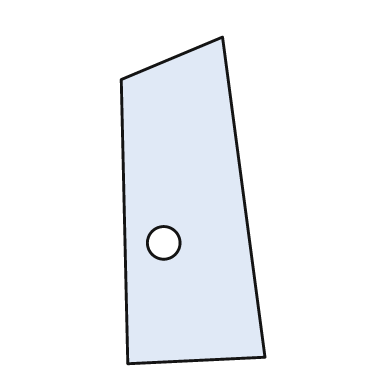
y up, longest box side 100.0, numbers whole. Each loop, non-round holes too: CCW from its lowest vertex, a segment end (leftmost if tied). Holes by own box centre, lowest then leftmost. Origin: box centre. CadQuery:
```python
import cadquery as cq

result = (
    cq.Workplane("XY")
    .moveTo(-20.0, -50.0)
    .lineTo(22.0, -48.0)
    .lineTo(9.0, 50.0)
    .lineTo(-22.0, 37.0)
    .close()
    .moveTo(-9.0, -13.0)
    .circle(5.0)
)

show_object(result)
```